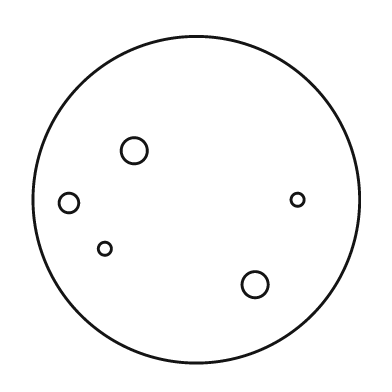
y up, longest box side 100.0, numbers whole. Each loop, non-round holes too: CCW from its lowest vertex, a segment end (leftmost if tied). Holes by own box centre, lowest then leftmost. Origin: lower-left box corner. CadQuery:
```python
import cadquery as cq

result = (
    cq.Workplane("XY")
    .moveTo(50.0, 50.0)
    .circle(50.0)
    .moveTo(68.0, 24.0)
    .circle(4.0)
    .moveTo(22.0, 35.0)
    .circle(2.0)
    .moveTo(11.0, 49.0)
    .circle(3.0)
    .moveTo(81.0, 50.0)
    .circle(2.0)
    .moveTo(31.0, 65.0)
    .circle(4.0)
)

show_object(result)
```